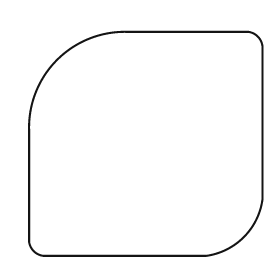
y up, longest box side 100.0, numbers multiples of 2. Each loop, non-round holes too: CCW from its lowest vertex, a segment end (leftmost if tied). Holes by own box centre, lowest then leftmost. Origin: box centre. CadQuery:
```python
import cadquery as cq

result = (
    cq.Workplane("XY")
    .moveTo(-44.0, -48.0)
    .lineTo(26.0, -48.0)
    .threePointArc((42.0, -40.0), (50.0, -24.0))
    .lineTo(50.0, 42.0)
    .threePointArc((48.0, 46.0), (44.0, 48.0))
    .lineTo(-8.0, 48.0)
    .threePointArc((-38.0, 36.0), (-50.0, 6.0))
    .lineTo(-50.0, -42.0)
    .threePointArc((-48.0, -46.0), (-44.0, -48.0))
    .close()
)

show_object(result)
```